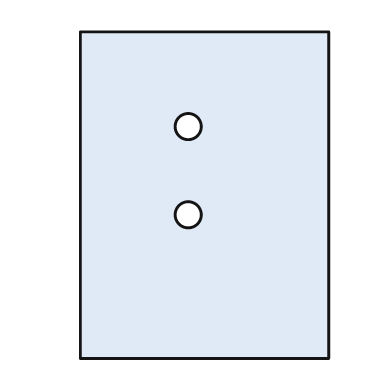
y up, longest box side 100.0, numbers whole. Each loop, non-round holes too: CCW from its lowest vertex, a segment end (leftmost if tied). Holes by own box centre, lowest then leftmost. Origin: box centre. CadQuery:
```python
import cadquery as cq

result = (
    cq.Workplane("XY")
    .moveTo(-38.0, -50.0)
    .lineTo(38.0, -50.0)
    .lineTo(38.0, 50.0)
    .lineTo(-38.0, 50.0)
    .close()
    .moveTo(-5.0, -6.0)
    .circle(4.0)
    .moveTo(-5.0, 21.0)
    .circle(4.0)
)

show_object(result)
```